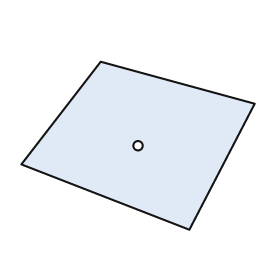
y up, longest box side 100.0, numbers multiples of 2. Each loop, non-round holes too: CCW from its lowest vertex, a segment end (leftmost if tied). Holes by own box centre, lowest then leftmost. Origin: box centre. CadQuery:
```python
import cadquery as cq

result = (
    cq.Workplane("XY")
    .moveTo(22.0, -36.0)
    .lineTo(50.0, 18.0)
    .lineTo(-16.0, 36.0)
    .lineTo(-50.0, -8.0)
    .close()
    .moveTo(0.0, 0.0)
    .circle(2.0)
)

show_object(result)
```